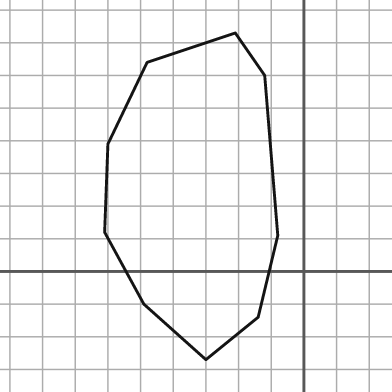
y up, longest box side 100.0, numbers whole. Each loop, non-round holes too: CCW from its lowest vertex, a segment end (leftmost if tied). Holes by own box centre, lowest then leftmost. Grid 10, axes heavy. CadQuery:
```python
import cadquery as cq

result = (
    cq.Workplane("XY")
    .moveTo(-30.0, -27.0)
    .lineTo(-14.0, -14.0)
    .lineTo(-8.0, 11.0)
    .lineTo(-12.0, 60.0)
    .lineTo(-21.0, 73.0)
    .lineTo(-48.0, 64.0)
    .lineTo(-60.0, 39.0)
    .lineTo(-61.0, 12.0)
    .lineTo(-49.0, -10.0)
    .close()
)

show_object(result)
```